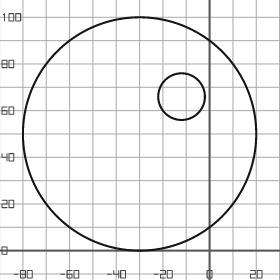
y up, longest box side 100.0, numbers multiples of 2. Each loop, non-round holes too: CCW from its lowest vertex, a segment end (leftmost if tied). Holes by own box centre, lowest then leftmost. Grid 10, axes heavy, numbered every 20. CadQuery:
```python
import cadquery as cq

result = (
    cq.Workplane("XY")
    .moveTo(-30.0, 50.0)
    .circle(50.0)
    .moveTo(-12.0, 66.0)
    .circle(10.0)
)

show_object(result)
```